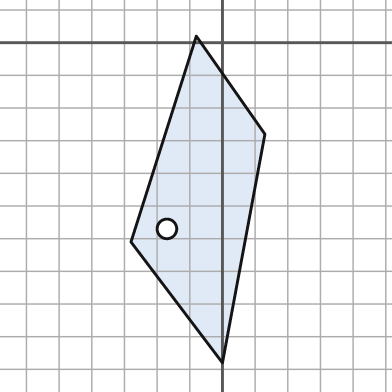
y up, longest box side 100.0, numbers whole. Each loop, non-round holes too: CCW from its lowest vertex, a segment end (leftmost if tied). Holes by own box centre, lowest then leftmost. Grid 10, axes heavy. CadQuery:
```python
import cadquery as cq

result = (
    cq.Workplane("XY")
    .moveTo(0.0, -98.0)
    .lineTo(13.0, -28.0)
    .lineTo(-8.0, 2.0)
    .lineTo(-28.0, -61.0)
    .close()
    .moveTo(-17.0, -57.0)
    .circle(3.0)
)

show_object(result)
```